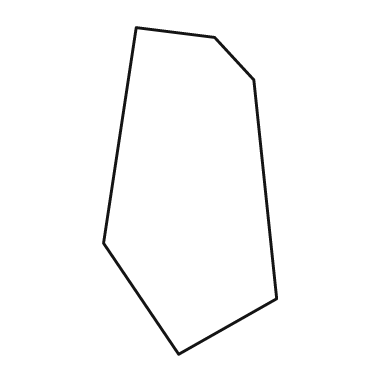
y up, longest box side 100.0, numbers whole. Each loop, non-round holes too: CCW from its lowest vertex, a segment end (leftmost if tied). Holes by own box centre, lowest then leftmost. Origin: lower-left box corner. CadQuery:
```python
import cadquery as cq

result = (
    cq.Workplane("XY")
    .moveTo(23.0, 0.0)
    .lineTo(53.0, 17.0)
    .lineTo(46.0, 84.0)
    .lineTo(34.0, 97.0)
    .lineTo(10.0, 100.0)
    .lineTo(0.0, 34.0)
    .close()
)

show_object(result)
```